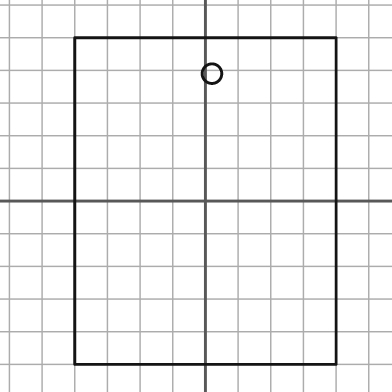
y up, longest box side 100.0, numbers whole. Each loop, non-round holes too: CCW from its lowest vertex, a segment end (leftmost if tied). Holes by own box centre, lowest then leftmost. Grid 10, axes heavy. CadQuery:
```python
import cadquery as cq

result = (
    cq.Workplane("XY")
    .moveTo(-40.0, -50.0)
    .lineTo(40.0, -50.0)
    .lineTo(40.0, 50.0)
    .lineTo(-40.0, 50.0)
    .close()
    .moveTo(2.0, 39.0)
    .circle(3.0)
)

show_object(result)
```